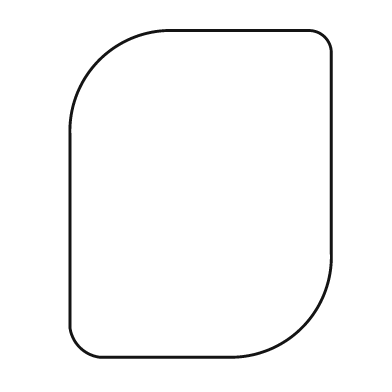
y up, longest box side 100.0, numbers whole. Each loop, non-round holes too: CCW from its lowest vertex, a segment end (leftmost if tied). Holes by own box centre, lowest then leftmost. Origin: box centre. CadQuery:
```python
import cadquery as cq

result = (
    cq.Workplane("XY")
    .moveTo(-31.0, -50.0)
    .lineTo(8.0, -50.0)
    .threePointArc((31.0, -41.0), (40.0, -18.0))
    .lineTo(40.0, 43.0)
    .threePointArc((38.0, 48.0), (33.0, 50.0))
    .lineTo(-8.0, 50.0)
    .threePointArc((-31.0, 41.0), (-40.0, 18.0))
    .lineTo(-40.0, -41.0)
    .threePointArc((-37.0, -47.0), (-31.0, -50.0))
    .close()
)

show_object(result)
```